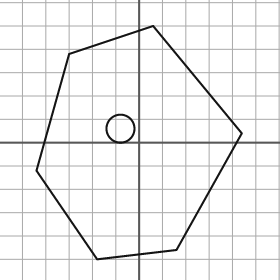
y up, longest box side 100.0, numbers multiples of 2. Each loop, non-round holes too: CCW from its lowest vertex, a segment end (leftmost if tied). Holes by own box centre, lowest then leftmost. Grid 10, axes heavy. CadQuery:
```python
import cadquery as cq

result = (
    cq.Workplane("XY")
    .moveTo(-18.0, -50.0)
    .lineTo(16.0, -46.0)
    .lineTo(44.0, 4.0)
    .lineTo(6.0, 50.0)
    .lineTo(-30.0, 38.0)
    .lineTo(-44.0, -12.0)
    .close()
    .moveTo(-8.0, 6.0)
    .circle(6.0)
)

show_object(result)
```